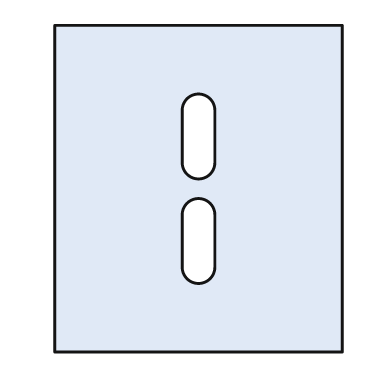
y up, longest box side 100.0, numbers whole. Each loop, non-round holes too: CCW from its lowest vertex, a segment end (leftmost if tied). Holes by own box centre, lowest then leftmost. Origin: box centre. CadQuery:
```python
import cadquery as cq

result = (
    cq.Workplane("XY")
    .moveTo(-44.0, -50.0)
    .lineTo(44.0, -50.0)
    .lineTo(44.0, 50.0)
    .lineTo(-44.0, 50.0)
    .close()
    .moveTo(-5.0, -24.0)
    .threePointArc((0.0, -29.0), (5.0, -24.0))
    .lineTo(5.0, -8.0)
    .threePointArc((0.0, -3.0), (-5.0, -8.0))
    .close()
    .moveTo(-5.0, 8.0)
    .threePointArc((0.0, 3.0), (5.0, 8.0))
    .lineTo(5.0, 24.0)
    .threePointArc((0.0, 29.0), (-5.0, 24.0))
    .close()
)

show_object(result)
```